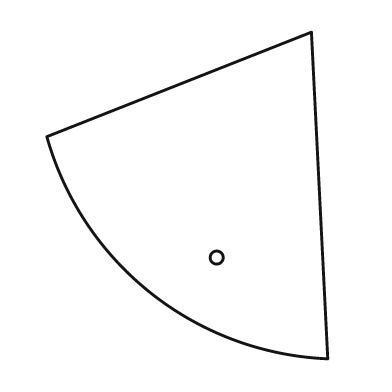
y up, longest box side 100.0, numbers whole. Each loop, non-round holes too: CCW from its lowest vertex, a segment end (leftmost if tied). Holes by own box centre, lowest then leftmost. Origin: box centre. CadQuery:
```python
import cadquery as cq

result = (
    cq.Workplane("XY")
    .moveTo(43.0, -50.0)
    .lineTo(38.0, 50.0)
    .lineTo(-43.0, 18.0)
    .threePointArc((-11.0, -30.0), (43.0, -50.0))
    .close()
    .moveTo(9.0, -19.0)
    .circle(2.0)
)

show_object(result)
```